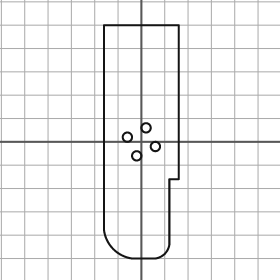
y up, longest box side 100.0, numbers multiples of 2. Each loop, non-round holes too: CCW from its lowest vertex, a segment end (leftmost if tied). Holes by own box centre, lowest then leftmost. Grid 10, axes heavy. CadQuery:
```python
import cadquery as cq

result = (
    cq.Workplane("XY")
    .moveTo(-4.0, -50.0)
    .lineTo(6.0, -50.0)
    .threePointArc((10.0, -48.0), (12.0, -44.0))
    .lineTo(12.0, -16.0)
    .lineTo(16.0, -16.0)
    .lineTo(16.0, 50.0)
    .lineTo(-16.0, 50.0)
    .lineTo(-16.0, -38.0)
    .threePointArc((-12.0, -46.0), (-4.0, -50.0))
    .close()
    .moveTo(-2.0, -6.0)
    .circle(2.0)
    .moveTo(6.0, -2.0)
    .circle(2.0)
    .moveTo(-6.0, 2.0)
    .circle(2.0)
    .moveTo(2.0, 6.0)
    .circle(2.0)
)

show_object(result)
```